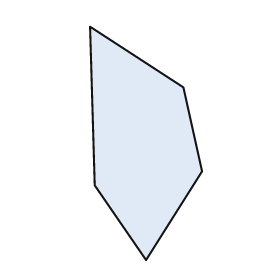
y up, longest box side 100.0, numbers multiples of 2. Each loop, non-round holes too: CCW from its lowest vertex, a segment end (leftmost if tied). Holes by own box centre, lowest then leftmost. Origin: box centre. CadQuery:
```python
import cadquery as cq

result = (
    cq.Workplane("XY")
    .moveTo(0.0, -50.0)
    .lineTo(24.0, -12.0)
    .lineTo(16.0, 24.0)
    .lineTo(-24.0, 50.0)
    .lineTo(-22.0, -18.0)
    .close()
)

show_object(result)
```